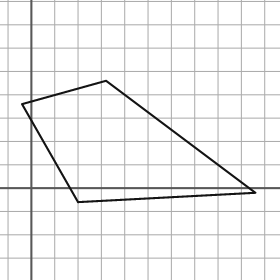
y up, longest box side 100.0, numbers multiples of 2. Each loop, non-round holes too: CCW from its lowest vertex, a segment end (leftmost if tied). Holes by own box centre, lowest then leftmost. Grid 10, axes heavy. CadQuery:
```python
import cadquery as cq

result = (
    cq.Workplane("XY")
    .moveTo(20.0, -6.0)
    .lineTo(96.0, -2.0)
    .lineTo(32.0, 46.0)
    .lineTo(-4.0, 36.0)
    .close()
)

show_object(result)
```